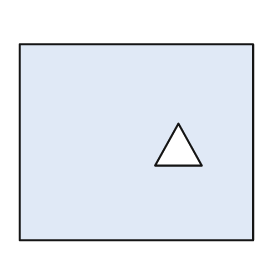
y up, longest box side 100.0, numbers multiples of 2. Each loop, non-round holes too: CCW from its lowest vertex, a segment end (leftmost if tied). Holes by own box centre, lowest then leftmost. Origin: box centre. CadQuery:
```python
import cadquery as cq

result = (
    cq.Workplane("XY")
    .moveTo(-50.0, -42.0)
    .lineTo(50.0, -42.0)
    .lineTo(50.0, 42.0)
    .lineTo(-50.0, 42.0)
    .close()
    .moveTo(8.0, -10.0)
    .lineTo(28.0, -10.0)
    .lineTo(18.0, 8.0)
    .close()
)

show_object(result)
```